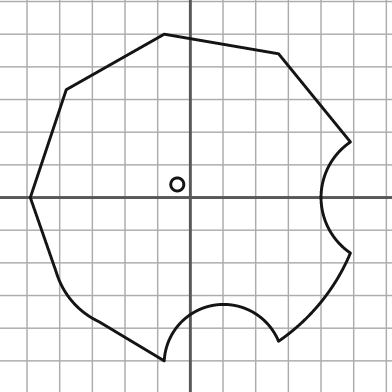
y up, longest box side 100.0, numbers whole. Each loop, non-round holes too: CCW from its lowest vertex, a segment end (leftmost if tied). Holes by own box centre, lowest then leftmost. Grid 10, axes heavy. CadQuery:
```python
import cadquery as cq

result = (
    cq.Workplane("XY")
    .moveTo(-8.0, -50.0)
    .threePointArc((7.0, -33.0), (27.0, -44.0))
    .threePointArc((40.0, -32.0), (49.0, -17.0))
    .threePointArc((40.0, 0.0), (49.0, 17.0))
    .lineTo(27.0, 44.0)
    .lineTo(-8.0, 50.0)
    .lineTo(-38.0, 33.0)
    .lineTo(-49.0, 0.0)
    .lineTo(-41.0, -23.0)
    .threePointArc((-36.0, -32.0), (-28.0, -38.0))
    .close()
    .moveTo(-4.0, 4.0)
    .circle(2.0)
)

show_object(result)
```